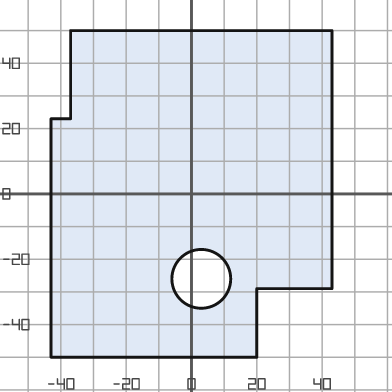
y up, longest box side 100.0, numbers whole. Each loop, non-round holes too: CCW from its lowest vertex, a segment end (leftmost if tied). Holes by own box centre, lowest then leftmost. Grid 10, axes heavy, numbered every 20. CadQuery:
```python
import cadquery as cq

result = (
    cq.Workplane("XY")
    .moveTo(-43.0, -50.0)
    .lineTo(20.0, -50.0)
    .lineTo(20.0, -29.0)
    .lineTo(43.0, -29.0)
    .lineTo(43.0, 50.0)
    .lineTo(-37.0, 50.0)
    .lineTo(-37.0, 23.0)
    .lineTo(-43.0, 23.0)
    .close()
    .moveTo(3.0, -26.0)
    .circle(9.0)
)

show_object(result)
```